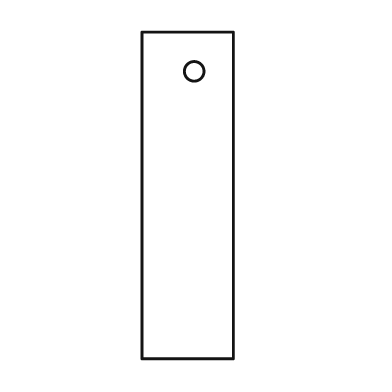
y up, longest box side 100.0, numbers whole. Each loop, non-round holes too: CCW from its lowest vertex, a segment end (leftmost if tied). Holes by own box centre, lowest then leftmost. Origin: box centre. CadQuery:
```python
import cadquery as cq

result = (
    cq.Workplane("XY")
    .moveTo(-14.0, -50.0)
    .lineTo(14.0, -50.0)
    .lineTo(14.0, 50.0)
    .lineTo(-14.0, 50.0)
    .close()
    .moveTo(2.0, 38.0)
    .circle(3.0)
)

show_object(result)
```